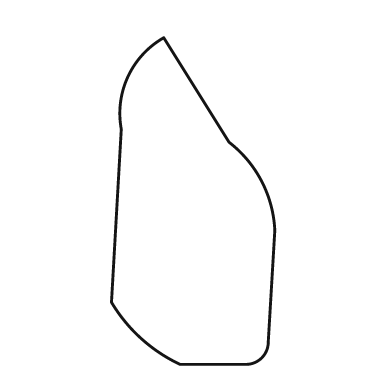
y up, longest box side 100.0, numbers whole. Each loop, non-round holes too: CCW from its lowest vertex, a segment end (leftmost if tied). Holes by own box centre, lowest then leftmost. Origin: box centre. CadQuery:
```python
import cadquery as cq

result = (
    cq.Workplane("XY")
    .moveTo(-4.0, -50.0)
    .lineTo(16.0, -50.0)
    .threePointArc((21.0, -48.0), (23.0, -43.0))
    .lineTo(25.0, -9.0)
    .threePointArc((21.0, 6.0), (11.0, 18.0))
    .lineTo(-9.0, 50.0)
    .threePointArc((-20.0, 38.0), (-22.0, 22.0))
    .lineTo(-25.0, -31.0)
    .threePointArc((-16.0, -42.0), (-4.0, -50.0))
    .close()
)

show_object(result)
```